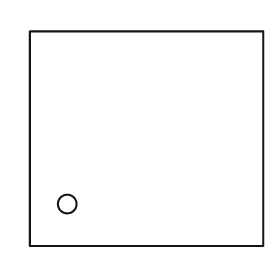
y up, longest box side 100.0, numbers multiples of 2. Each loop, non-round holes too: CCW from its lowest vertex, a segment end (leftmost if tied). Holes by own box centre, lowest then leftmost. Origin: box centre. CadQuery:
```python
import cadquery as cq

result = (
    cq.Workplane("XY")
    .moveTo(-50.0, -46.0)
    .lineTo(50.0, -46.0)
    .lineTo(50.0, 46.0)
    .lineTo(-50.0, 46.0)
    .close()
    .moveTo(-34.0, -28.0)
    .circle(4.0)
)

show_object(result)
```